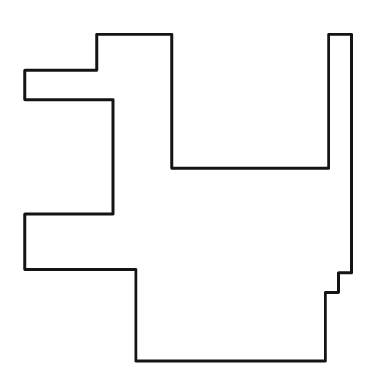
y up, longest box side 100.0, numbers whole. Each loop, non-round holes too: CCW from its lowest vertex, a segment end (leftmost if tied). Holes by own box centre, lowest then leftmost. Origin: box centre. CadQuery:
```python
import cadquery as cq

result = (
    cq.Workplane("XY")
    .moveTo(-16.0, -50.0)
    .lineTo(42.0, -50.0)
    .lineTo(42.0, -29.0)
    .lineTo(46.0, -29.0)
    .lineTo(46.0, -23.0)
    .lineTo(50.0, -23.0)
    .lineTo(50.0, 50.0)
    .lineTo(43.0, 50.0)
    .lineTo(43.0, 9.0)
    .lineTo(-5.0, 9.0)
    .lineTo(-5.0, 50.0)
    .lineTo(-28.0, 50.0)
    .lineTo(-28.0, 39.0)
    .lineTo(-50.0, 39.0)
    .lineTo(-50.0, 30.0)
    .lineTo(-23.0, 30.0)
    .lineTo(-23.0, -5.0)
    .lineTo(-50.0, -5.0)
    .lineTo(-50.0, -22.0)
    .lineTo(-16.0, -22.0)
    .close()
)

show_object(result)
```